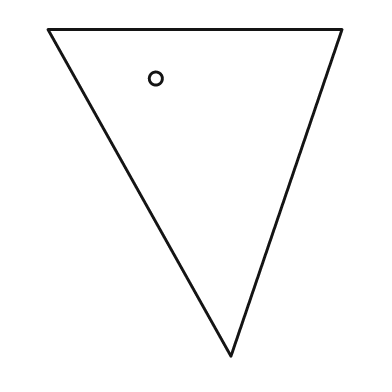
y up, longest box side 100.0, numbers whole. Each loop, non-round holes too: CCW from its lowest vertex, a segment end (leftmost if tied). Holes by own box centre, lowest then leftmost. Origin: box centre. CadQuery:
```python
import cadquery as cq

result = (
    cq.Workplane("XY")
    .moveTo(11.0, -50.0)
    .lineTo(45.0, 50.0)
    .lineTo(-45.0, 50.0)
    .close()
    .moveTo(-12.0, 35.0)
    .circle(2.0)
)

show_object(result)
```